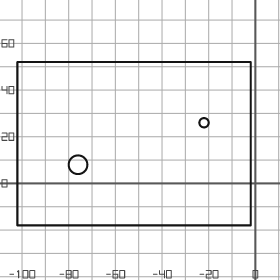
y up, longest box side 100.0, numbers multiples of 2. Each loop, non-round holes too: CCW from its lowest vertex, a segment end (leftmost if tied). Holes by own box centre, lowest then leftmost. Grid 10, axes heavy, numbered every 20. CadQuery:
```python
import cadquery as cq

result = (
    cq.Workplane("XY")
    .moveTo(-102.0, -18.0)
    .lineTo(-2.0, -18.0)
    .lineTo(-2.0, 52.0)
    .lineTo(-102.0, 52.0)
    .close()
    .moveTo(-76.0, 8.0)
    .circle(4.0)
    .moveTo(-22.0, 26.0)
    .circle(2.0)
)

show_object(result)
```